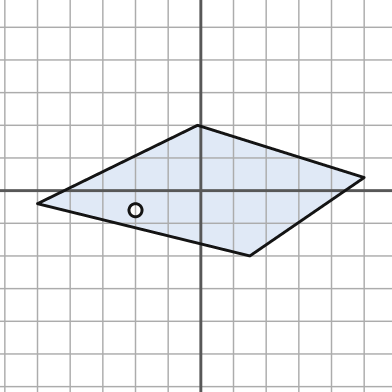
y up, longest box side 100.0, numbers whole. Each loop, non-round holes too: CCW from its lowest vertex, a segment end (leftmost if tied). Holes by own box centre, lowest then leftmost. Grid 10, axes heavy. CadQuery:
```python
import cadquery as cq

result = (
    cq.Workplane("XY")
    .moveTo(15.0, -20.0)
    .lineTo(50.0, 4.0)
    .lineTo(-1.0, 20.0)
    .lineTo(-50.0, -4.0)
    .close()
    .moveTo(-20.0, -6.0)
    .circle(2.0)
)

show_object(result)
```